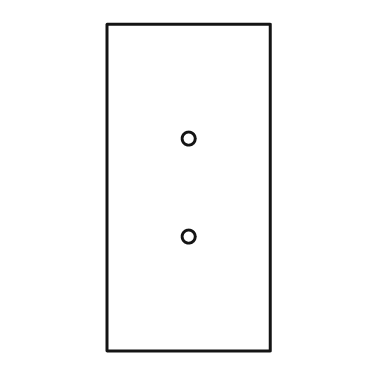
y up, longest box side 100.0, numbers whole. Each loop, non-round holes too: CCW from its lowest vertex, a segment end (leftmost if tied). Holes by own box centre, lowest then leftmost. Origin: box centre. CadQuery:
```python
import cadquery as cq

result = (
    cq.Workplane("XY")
    .moveTo(-25.0, -50.0)
    .lineTo(25.0, -50.0)
    .lineTo(25.0, 50.0)
    .lineTo(-25.0, 50.0)
    .close()
    .moveTo(0.0, -15.0)
    .circle(2.0)
    .moveTo(0.0, 15.0)
    .circle(2.0)
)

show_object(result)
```